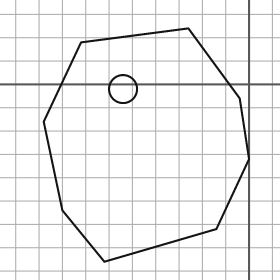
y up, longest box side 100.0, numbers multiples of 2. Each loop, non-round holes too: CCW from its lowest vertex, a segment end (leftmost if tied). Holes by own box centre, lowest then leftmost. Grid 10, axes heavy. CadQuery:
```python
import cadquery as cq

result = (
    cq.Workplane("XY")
    .moveTo(-62.0, -76.0)
    .lineTo(-14.0, -62.0)
    .lineTo(0.0, -32.0)
    .lineTo(-4.0, -6.0)
    .lineTo(-26.0, 24.0)
    .lineTo(-72.0, 18.0)
    .lineTo(-88.0, -16.0)
    .lineTo(-80.0, -54.0)
    .close()
    .moveTo(-54.0, -2.0)
    .circle(6.0)
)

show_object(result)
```